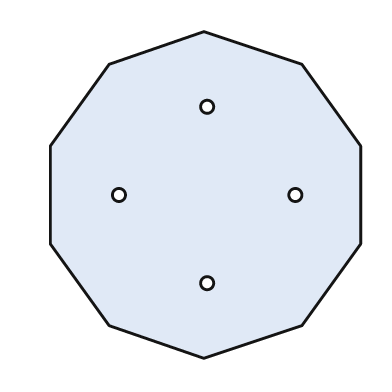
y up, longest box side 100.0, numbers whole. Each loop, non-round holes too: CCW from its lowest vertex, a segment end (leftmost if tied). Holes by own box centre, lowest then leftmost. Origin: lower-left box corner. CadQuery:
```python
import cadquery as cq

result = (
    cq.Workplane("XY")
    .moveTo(47.0, 0.0)
    .lineTo(77.0, 10.0)
    .lineTo(95.0, 35.0)
    .lineTo(95.0, 65.0)
    .lineTo(77.0, 90.0)
    .lineTo(47.0, 100.0)
    .lineTo(18.0, 90.0)
    .lineTo(0.0, 65.0)
    .lineTo(0.0, 35.0)
    .lineTo(18.0, 10.0)
    .close()
    .moveTo(48.0, 23.0)
    .circle(2.0)
    .moveTo(21.0, 50.0)
    .circle(2.0)
    .moveTo(75.0, 50.0)
    .circle(2.0)
    .moveTo(48.0, 77.0)
    .circle(2.0)
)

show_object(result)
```